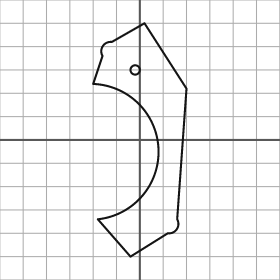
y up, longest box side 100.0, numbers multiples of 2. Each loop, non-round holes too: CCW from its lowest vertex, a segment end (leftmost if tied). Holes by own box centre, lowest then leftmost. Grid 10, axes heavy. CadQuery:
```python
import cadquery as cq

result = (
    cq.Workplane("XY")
    .moveTo(-4.0, -50.0)
    .lineTo(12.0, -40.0)
    .threePointArc((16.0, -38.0), (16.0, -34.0))
    .lineTo(20.0, 22.0)
    .lineTo(2.0, 50.0)
    .lineTo(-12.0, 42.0)
    .threePointArc((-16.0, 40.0), (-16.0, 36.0))
    .lineTo(-20.0, 24.0)
    .threePointArc((8.0, -4.0), (-18.0, -34.0))
    .close()
    .moveTo(-2.0, 30.0)
    .circle(2.0)
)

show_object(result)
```